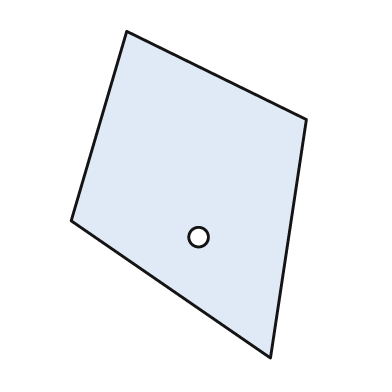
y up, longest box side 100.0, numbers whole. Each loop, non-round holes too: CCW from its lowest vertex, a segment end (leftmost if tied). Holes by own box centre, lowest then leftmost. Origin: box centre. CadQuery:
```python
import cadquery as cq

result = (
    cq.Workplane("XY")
    .moveTo(25.0, -50.0)
    .lineTo(36.0, 23.0)
    .lineTo(-19.0, 50.0)
    .lineTo(-36.0, -8.0)
    .close()
    .moveTo(3.0, -13.0)
    .circle(3.0)
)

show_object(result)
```